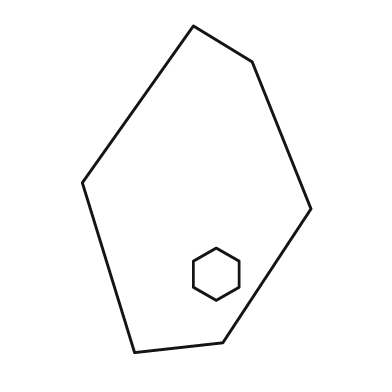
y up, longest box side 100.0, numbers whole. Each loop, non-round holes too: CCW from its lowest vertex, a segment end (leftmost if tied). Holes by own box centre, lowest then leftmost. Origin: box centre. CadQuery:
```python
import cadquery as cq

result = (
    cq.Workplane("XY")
    .moveTo(-19.0, -50.0)
    .lineTo(8.0, -47.0)
    .lineTo(35.0, -6.0)
    .lineTo(17.0, 39.0)
    .lineTo(-1.0, 50.0)
    .lineTo(-35.0, 2.0)
    .close()
    .moveTo(6.0, -34.0)
    .lineTo(13.0, -30.0)
    .lineTo(13.0, -22.0)
    .lineTo(6.0, -18.0)
    .lineTo(-1.0, -22.0)
    .lineTo(-1.0, -30.0)
    .close()
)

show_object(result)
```